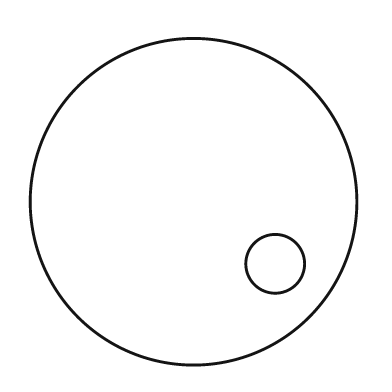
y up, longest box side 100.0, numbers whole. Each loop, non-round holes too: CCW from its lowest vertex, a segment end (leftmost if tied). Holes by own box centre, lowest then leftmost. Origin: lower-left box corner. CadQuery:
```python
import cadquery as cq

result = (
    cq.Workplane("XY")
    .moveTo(50.0, 50.0)
    .circle(50.0)
    .moveTo(75.0, 31.0)
    .circle(9.0)
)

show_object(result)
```